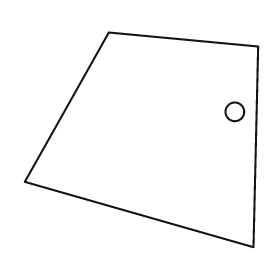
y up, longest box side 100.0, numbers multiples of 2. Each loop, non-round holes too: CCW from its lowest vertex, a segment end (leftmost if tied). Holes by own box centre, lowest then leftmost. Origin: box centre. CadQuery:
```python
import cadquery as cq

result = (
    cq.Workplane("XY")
    .moveTo(48.0, -46.0)
    .lineTo(50.0, 40.0)
    .lineTo(-14.0, 46.0)
    .lineTo(-50.0, -18.0)
    .close()
    .moveTo(40.0, 12.0)
    .circle(4.0)
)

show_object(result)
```